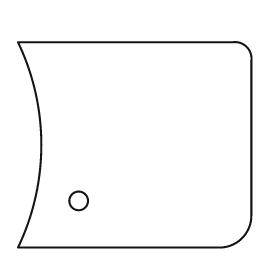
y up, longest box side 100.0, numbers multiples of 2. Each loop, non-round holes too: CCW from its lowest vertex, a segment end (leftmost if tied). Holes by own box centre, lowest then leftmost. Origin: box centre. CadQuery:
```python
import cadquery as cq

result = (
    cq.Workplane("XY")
    .moveTo(-50.0, -44.0)
    .lineTo(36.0, -44.0)
    .threePointArc((46.0, -40.0), (50.0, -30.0))
    .lineTo(50.0, 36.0)
    .threePointArc((48.0, 42.0), (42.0, 44.0))
    .lineTo(-50.0, 44.0)
    .threePointArc((-40.0, 0.0), (-50.0, -44.0))
    .close()
    .moveTo(-24.0, -24.0)
    .circle(4.0)
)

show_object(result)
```